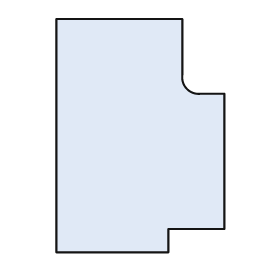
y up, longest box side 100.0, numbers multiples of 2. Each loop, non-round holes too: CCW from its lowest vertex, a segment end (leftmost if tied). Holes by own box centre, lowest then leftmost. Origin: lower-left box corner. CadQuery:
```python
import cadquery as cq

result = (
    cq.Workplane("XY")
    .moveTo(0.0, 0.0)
    .lineTo(48.0, 0.0)
    .lineTo(48.0, 10.0)
    .lineTo(72.0, 10.0)
    .lineTo(72.0, 68.0)
    .lineTo(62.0, 68.0)
    .threePointArc((56.0, 70.0), (54.0, 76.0))
    .lineTo(54.0, 100.0)
    .lineTo(0.0, 100.0)
    .close()
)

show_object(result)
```